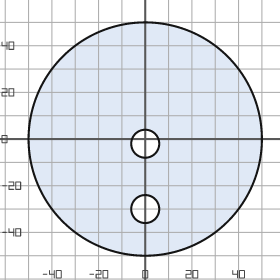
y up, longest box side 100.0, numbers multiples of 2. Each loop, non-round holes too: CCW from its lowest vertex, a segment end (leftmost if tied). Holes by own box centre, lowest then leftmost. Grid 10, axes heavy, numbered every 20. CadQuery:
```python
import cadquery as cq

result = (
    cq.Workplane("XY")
    .moveTo(0.0, 0.0)
    .circle(50.0)
    .moveTo(0.0, -30.0)
    .circle(6.0)
    .moveTo(0.0, -2.0)
    .circle(6.0)
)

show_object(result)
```